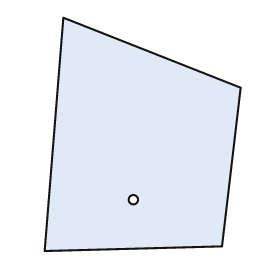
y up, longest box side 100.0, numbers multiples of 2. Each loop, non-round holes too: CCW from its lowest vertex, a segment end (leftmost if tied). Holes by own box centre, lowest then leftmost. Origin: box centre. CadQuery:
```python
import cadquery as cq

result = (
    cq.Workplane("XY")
    .moveTo(-42.0, -50.0)
    .lineTo(34.0, -48.0)
    .lineTo(42.0, 20.0)
    .lineTo(-34.0, 50.0)
    .close()
    .moveTo(-4.0, -28.0)
    .circle(2.0)
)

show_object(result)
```